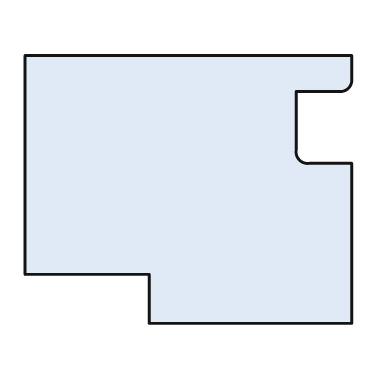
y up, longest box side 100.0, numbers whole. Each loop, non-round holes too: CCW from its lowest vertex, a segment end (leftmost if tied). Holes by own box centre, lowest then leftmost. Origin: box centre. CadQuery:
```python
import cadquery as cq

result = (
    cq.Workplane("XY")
    .moveTo(-12.0, -41.0)
    .lineTo(50.0, -41.0)
    .lineTo(50.0, 8.0)
    .lineTo(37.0, 8.0)
    .threePointArc((34.0, 9.0), (33.0, 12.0))
    .lineTo(33.0, 30.0)
    .lineTo(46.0, 30.0)
    .threePointArc((49.0, 31.0), (50.0, 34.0))
    .lineTo(50.0, 41.0)
    .lineTo(-50.0, 41.0)
    .lineTo(-50.0, -26.0)
    .lineTo(-12.0, -26.0)
    .close()
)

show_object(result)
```